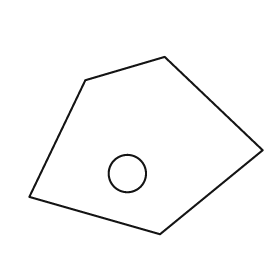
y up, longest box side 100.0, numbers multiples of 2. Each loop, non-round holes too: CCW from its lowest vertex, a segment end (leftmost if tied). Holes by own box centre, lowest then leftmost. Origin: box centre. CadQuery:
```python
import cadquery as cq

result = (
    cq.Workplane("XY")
    .moveTo(6.0, -38.0)
    .lineTo(50.0, -2.0)
    .lineTo(8.0, 38.0)
    .lineTo(-26.0, 28.0)
    .lineTo(-50.0, -22.0)
    .close()
    .moveTo(-8.0, -12.0)
    .circle(8.0)
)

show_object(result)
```